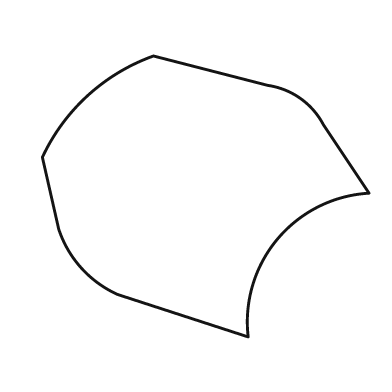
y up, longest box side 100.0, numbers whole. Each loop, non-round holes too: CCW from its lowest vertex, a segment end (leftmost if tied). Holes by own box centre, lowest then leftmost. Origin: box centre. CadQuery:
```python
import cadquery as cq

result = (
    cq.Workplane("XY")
    .moveTo(13.0, -43.0)
    .threePointArc((22.0, -13.0), (50.0, 1.0))
    .lineTo(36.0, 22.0)
    .threePointArc((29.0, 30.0), (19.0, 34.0))
    .lineTo(-16.0, 43.0)
    .threePointArc((-36.0, 31.0), (-50.0, 12.0))
    .lineTo(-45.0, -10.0)
    .threePointArc((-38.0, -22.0), (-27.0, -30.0))
    .close()
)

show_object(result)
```